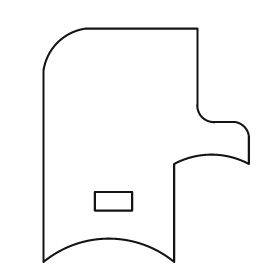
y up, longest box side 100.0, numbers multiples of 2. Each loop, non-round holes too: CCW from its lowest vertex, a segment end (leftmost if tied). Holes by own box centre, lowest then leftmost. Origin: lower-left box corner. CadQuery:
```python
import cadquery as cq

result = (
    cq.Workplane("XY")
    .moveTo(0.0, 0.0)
    .threePointArc((28.0, 10.0), (56.0, 0.0))
    .lineTo(56.0, 42.0)
    .threePointArc((72.0, 46.0), (88.0, 42.0))
    .lineTo(88.0, 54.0)
    .threePointArc((86.0, 58.0), (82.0, 60.0))
    .lineTo(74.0, 60.0)
    .threePointArc((68.0, 62.0), (66.0, 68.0))
    .lineTo(66.0, 100.0)
    .lineTo(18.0, 100.0)
    .threePointArc((6.0, 94.0), (0.0, 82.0))
    .close()
    .moveTo(22.0, 22.0)
    .lineTo(38.0, 22.0)
    .lineTo(38.0, 30.0)
    .lineTo(22.0, 30.0)
    .close()
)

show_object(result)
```